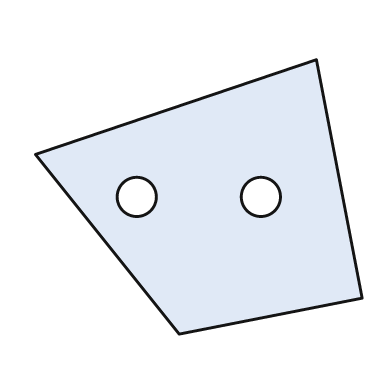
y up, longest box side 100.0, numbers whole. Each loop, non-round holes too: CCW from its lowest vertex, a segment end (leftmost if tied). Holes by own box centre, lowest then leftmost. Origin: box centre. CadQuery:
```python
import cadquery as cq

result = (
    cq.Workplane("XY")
    .moveTo(-6.0, -42.0)
    .lineTo(50.0, -31.0)
    .lineTo(36.0, 42.0)
    .lineTo(-50.0, 13.0)
    .close()
    .moveTo(-19.0, 0.0)
    .circle(6.0)
    .moveTo(19.0, 0.0)
    .circle(6.0)
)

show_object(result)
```